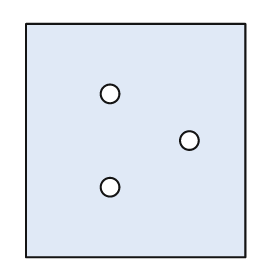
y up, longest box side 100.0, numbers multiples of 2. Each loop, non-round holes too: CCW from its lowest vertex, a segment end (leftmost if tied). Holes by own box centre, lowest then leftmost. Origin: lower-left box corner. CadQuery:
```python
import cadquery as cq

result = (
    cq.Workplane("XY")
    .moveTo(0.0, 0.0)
    .lineTo(94.0, 0.0)
    .lineTo(94.0, 100.0)
    .lineTo(0.0, 100.0)
    .close()
    .moveTo(36.0, 30.0)
    .circle(4.0)
    .moveTo(70.0, 50.0)
    .circle(4.0)
    .moveTo(36.0, 70.0)
    .circle(4.0)
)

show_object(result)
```